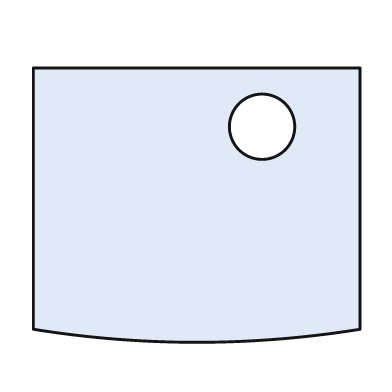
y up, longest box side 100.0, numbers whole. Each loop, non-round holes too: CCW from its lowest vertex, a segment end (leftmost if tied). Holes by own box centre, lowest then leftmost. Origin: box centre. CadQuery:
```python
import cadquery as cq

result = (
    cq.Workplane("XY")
    .moveTo(-50.0, -38.0)
    .threePointArc((0.0, -42.0), (50.0, -38.0))
    .lineTo(50.0, 42.0)
    .lineTo(-50.0, 42.0)
    .close()
    .moveTo(20.0, 24.0)
    .circle(10.0)
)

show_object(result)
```